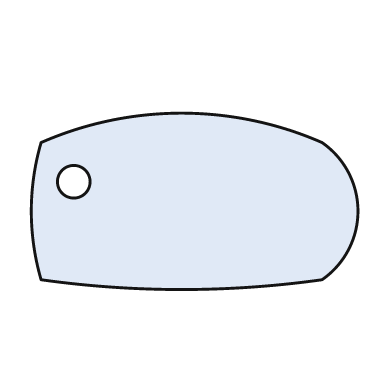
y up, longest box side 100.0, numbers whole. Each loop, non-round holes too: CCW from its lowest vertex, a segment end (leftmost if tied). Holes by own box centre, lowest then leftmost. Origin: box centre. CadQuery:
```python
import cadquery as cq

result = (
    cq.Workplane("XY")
    .moveTo(-47.0, -24.0)
    .threePointArc((-4.0, -27.0), (39.0, -24.0))
    .threePointArc((50.0, -3.0), (39.0, 18.0))
    .threePointArc((-4.0, 27.0), (-47.0, 18.0))
    .threePointArc((-50.0, -3.0), (-47.0, -24.0))
    .close()
    .moveTo(-37.0, 6.0)
    .circle(5.0)
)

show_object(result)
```